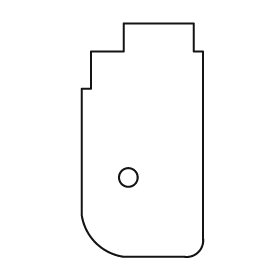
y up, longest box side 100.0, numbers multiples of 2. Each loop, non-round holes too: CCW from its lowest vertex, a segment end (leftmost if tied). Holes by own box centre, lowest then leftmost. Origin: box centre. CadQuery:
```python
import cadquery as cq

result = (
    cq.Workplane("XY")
    .moveTo(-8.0, -50.0)
    .lineTo(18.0, -50.0)
    .threePointArc((24.0, -48.0), (26.0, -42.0))
    .lineTo(26.0, 38.0)
    .lineTo(22.0, 38.0)
    .lineTo(22.0, 50.0)
    .lineTo(-8.0, 50.0)
    .lineTo(-8.0, 38.0)
    .lineTo(-22.0, 38.0)
    .lineTo(-22.0, 22.0)
    .lineTo(-26.0, 22.0)
    .lineTo(-26.0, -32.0)
    .threePointArc((-20.0, -44.0), (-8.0, -50.0))
    .close()
    .moveTo(-6.0, -16.0)
    .circle(4.0)
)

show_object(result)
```